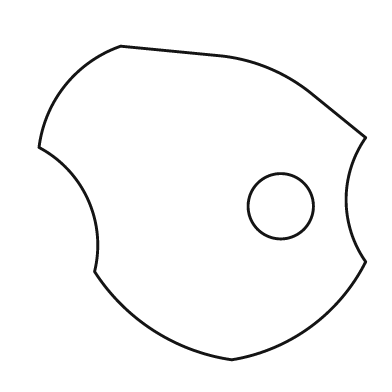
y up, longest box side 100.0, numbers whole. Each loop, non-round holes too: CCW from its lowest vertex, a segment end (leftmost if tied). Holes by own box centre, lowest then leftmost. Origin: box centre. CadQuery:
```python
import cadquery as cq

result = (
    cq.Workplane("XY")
    .moveTo(9.0, -48.0)
    .threePointArc((33.0, -38.0), (50.0, -18.0))
    .threePointArc((44.0, 1.0), (50.0, 20.0))
    .lineTo(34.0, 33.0)
    .threePointArc((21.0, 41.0), (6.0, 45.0))
    .lineTo(-25.0, 48.0)
    .threePointArc((-42.0, 36.0), (-50.0, 17.0))
    .threePointArc((-35.0, 1.0), (-33.0, -21.0))
    .threePointArc((-15.0, -39.0), (9.0, -48.0))
    .close()
    .moveTo(24.0, -1.0)
    .circle(10.0)
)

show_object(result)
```